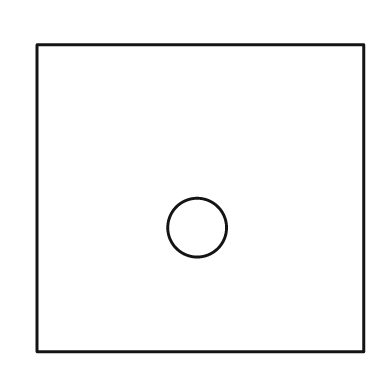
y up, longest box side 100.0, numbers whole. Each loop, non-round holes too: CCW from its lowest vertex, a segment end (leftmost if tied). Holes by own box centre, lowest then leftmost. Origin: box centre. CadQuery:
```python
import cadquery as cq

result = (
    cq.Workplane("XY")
    .moveTo(-50.0, -47.0)
    .lineTo(50.0, -47.0)
    .lineTo(50.0, 47.0)
    .lineTo(-50.0, 47.0)
    .close()
    .moveTo(-1.0, -9.0)
    .circle(9.0)
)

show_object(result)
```